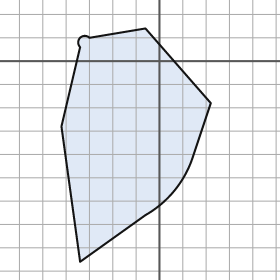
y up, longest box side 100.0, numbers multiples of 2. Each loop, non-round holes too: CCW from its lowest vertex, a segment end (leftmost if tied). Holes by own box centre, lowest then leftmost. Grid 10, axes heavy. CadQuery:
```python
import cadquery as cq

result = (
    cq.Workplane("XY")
    .moveTo(-34.0, -86.0)
    .lineTo(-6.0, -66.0)
    .threePointArc((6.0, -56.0), (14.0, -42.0))
    .lineTo(22.0, -18.0)
    .lineTo(-6.0, 14.0)
    .lineTo(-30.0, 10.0)
    .threePointArc((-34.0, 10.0), (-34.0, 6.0))
    .lineTo(-42.0, -28.0)
    .close()
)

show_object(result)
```